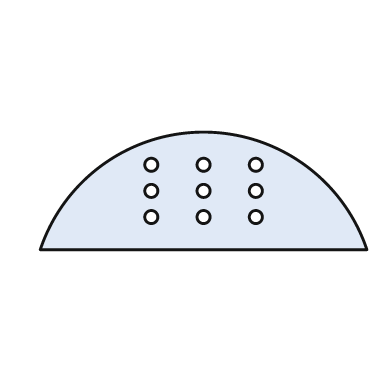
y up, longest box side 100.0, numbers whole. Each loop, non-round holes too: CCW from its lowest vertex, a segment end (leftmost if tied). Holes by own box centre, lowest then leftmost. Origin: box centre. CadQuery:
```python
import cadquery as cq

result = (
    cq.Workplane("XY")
    .moveTo(-50.0, -18.0)
    .lineTo(50.0, -18.0)
    .threePointArc((0.0, 18.0), (-50.0, -18.0))
    .close()
    .moveTo(-16.0, -8.0)
    .circle(2.0)
    .moveTo(0.0, -8.0)
    .circle(2.0)
    .moveTo(16.0, -8.0)
    .circle(2.0)
    .moveTo(-16.0, 0.0)
    .circle(2.0)
    .moveTo(0.0, 0.0)
    .circle(2.0)
    .moveTo(16.0, 0.0)
    .circle(2.0)
    .moveTo(-16.0, 8.0)
    .circle(2.0)
    .moveTo(0.0, 8.0)
    .circle(2.0)
    .moveTo(16.0, 8.0)
    .circle(2.0)
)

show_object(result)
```